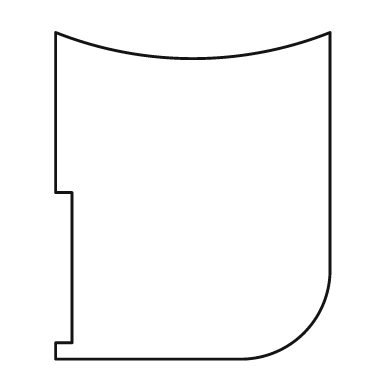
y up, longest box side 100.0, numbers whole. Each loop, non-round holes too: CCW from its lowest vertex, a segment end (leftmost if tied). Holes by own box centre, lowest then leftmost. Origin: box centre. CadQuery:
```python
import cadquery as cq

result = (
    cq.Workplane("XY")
    .moveTo(-42.0, -50.0)
    .lineTo(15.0, -50.0)
    .threePointArc((34.0, -42.0), (42.0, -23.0))
    .lineTo(42.0, 50.0)
    .threePointArc((0.0, 42.0), (-42.0, 50.0))
    .lineTo(-42.0, 1.0)
    .lineTo(-37.0, 1.0)
    .lineTo(-37.0, -45.0)
    .lineTo(-42.0, -45.0)
    .close()
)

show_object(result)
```